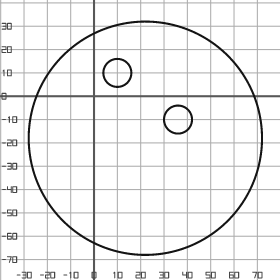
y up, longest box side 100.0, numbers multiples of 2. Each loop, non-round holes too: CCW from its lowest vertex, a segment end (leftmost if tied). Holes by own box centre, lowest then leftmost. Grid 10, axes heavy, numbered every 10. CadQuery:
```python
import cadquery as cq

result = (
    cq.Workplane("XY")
    .moveTo(22.0, -18.0)
    .circle(50.0)
    .moveTo(36.0, -10.0)
    .circle(6.0)
    .moveTo(10.0, 10.0)
    .circle(6.0)
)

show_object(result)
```